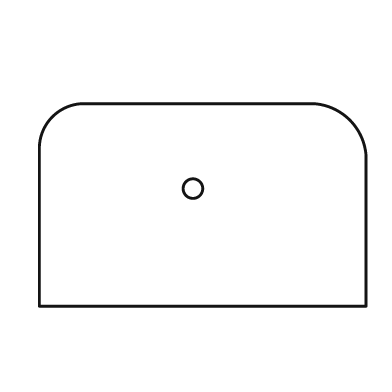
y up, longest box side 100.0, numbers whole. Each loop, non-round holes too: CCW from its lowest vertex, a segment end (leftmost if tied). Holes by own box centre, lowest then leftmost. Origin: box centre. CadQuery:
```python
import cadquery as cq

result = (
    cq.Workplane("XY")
    .moveTo(-50.0, -31.0)
    .lineTo(50.0, -31.0)
    .lineTo(50.0, 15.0)
    .threePointArc((45.0, 26.0), (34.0, 31.0))
    .lineTo(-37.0, 31.0)
    .threePointArc((-46.0, 27.0), (-50.0, 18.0))
    .close()
    .moveTo(-3.0, 5.0)
    .circle(3.0)
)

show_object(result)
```